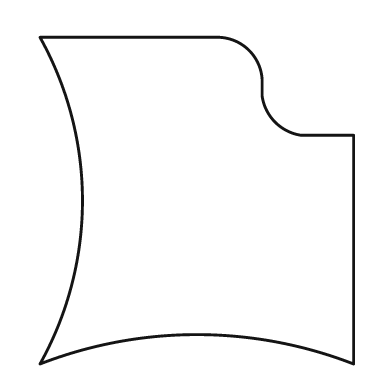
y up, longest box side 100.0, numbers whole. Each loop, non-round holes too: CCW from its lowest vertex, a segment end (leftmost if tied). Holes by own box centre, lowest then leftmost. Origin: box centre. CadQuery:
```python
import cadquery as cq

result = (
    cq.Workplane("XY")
    .moveTo(-48.0, -50.0)
    .threePointArc((0.0, -41.0), (48.0, -50.0))
    .lineTo(48.0, 20.0)
    .lineTo(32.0, 20.0)
    .threePointArc((24.0, 24.0), (20.0, 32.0))
    .lineTo(20.0, 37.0)
    .threePointArc((16.0, 46.0), (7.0, 50.0))
    .lineTo(-48.0, 50.0)
    .threePointArc((-35.0, 0.0), (-48.0, -50.0))
    .close()
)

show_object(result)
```